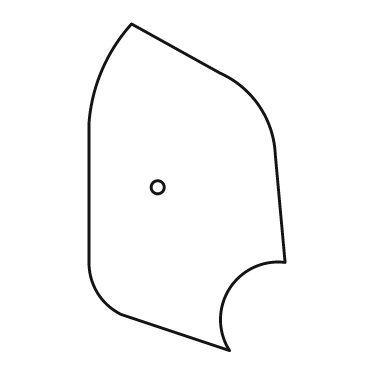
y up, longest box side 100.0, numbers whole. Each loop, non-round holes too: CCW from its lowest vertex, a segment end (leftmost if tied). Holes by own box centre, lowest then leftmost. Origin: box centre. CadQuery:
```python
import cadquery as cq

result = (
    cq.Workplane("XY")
    .moveTo(13.0, -50.0)
    .threePointArc((13.0, -31.0), (30.0, -23.0))
    .lineTo(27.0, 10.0)
    .threePointArc((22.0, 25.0), (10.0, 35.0))
    .lineTo(-17.0, 50.0)
    .threePointArc((-26.0, 36.0), (-30.0, 20.0))
    .lineTo(-30.0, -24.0)
    .threePointArc((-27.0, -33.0), (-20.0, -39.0))
    .close()
    .moveTo(-9.0, 0.0)
    .circle(2.0)
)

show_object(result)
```